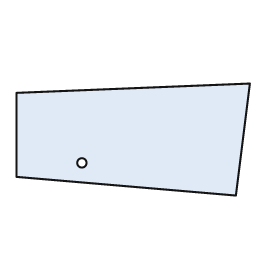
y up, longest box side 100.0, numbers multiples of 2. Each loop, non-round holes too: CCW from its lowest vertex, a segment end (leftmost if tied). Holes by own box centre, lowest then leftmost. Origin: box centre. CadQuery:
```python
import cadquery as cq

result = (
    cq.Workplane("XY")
    .moveTo(44.0, -24.0)
    .lineTo(50.0, 24.0)
    .lineTo(-50.0, 20.0)
    .lineTo(-50.0, -16.0)
    .close()
    .moveTo(-22.0, -10.0)
    .circle(2.0)
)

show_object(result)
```